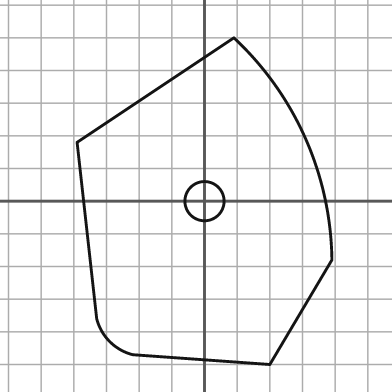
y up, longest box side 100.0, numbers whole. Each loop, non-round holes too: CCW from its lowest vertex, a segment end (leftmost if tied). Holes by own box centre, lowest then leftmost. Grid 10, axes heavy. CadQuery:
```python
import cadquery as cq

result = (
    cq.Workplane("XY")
    .moveTo(20.0, -50.0)
    .lineTo(39.0, -18.0)
    .threePointArc((31.0, 19.0), (9.0, 50.0))
    .lineTo(-39.0, 18.0)
    .lineTo(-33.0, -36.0)
    .threePointArc((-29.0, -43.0), (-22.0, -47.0))
    .close()
    .moveTo(0.0, 0.0)
    .circle(6.0)
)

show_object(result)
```